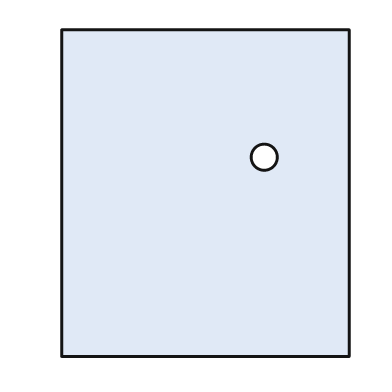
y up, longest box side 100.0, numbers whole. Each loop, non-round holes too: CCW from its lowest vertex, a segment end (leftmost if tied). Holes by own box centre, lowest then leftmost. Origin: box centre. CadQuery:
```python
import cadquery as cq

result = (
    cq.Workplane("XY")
    .moveTo(-44.0, -50.0)
    .lineTo(44.0, -50.0)
    .lineTo(44.0, 50.0)
    .lineTo(-44.0, 50.0)
    .close()
    .moveTo(18.0, 11.0)
    .circle(4.0)
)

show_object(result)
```